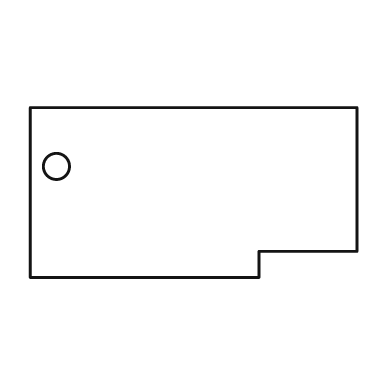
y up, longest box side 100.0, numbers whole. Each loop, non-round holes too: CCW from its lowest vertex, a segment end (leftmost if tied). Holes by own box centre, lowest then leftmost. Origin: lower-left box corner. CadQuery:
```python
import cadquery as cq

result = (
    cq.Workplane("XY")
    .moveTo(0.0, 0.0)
    .lineTo(70.0, 0.0)
    .lineTo(70.0, 8.0)
    .lineTo(100.0, 8.0)
    .lineTo(100.0, 52.0)
    .lineTo(0.0, 52.0)
    .close()
    .moveTo(8.0, 34.0)
    .circle(4.0)
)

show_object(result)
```